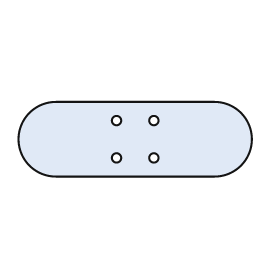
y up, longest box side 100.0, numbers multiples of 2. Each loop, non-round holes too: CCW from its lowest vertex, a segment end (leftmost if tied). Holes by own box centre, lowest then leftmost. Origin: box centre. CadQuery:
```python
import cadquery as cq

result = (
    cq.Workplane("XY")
    .moveTo(-34.0, -16.0)
    .lineTo(34.0, -16.0)
    .threePointArc((50.0, 0.0), (34.0, 16.0))
    .lineTo(-34.0, 16.0)
    .threePointArc((-50.0, 0.0), (-34.0, -16.0))
    .close()
    .moveTo(-8.0, -8.0)
    .circle(2.0)
    .moveTo(8.0, -8.0)
    .circle(2.0)
    .moveTo(-8.0, 8.0)
    .circle(2.0)
    .moveTo(8.0, 8.0)
    .circle(2.0)
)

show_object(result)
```